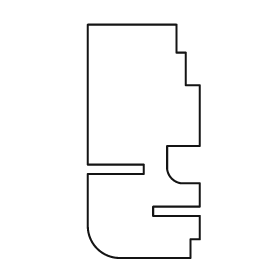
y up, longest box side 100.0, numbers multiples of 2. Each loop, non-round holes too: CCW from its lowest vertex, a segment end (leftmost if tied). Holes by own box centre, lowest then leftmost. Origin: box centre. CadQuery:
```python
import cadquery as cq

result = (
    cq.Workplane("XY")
    .moveTo(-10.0, -50.0)
    .lineTo(20.0, -50.0)
    .lineTo(20.0, -42.0)
    .lineTo(24.0, -42.0)
    .lineTo(24.0, -32.0)
    .lineTo(4.0, -32.0)
    .lineTo(4.0, -28.0)
    .lineTo(24.0, -28.0)
    .lineTo(24.0, -18.0)
    .lineTo(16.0, -18.0)
    .threePointArc((12.0, -16.0), (10.0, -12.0))
    .lineTo(10.0, -2.0)
    .lineTo(24.0, -2.0)
    .lineTo(24.0, 24.0)
    .lineTo(18.0, 24.0)
    .lineTo(18.0, 38.0)
    .lineTo(14.0, 38.0)
    .lineTo(14.0, 50.0)
    .lineTo(-24.0, 50.0)
    .lineTo(-24.0, -10.0)
    .lineTo(0.0, -10.0)
    .lineTo(0.0, -14.0)
    .lineTo(-24.0, -14.0)
    .lineTo(-24.0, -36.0)
    .threePointArc((-20.0, -46.0), (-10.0, -50.0))
    .close()
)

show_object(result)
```